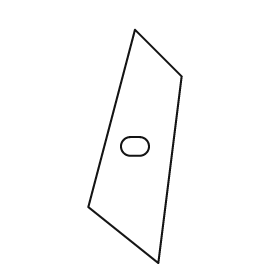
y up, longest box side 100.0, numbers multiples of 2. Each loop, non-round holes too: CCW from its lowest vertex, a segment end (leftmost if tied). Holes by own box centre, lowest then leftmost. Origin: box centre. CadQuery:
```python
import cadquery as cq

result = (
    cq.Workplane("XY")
    .moveTo(10.0, -50.0)
    .lineTo(20.0, 30.0)
    .lineTo(0.0, 50.0)
    .lineTo(-20.0, -26.0)
    .close()
    .moveTo(-2.0, -4.0)
    .lineTo(2.0, -4.0)
    .threePointArc((6.0, 0.0), (2.0, 4.0))
    .lineTo(-2.0, 4.0)
    .threePointArc((-6.0, 0.0), (-2.0, -4.0))
    .close()
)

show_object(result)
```